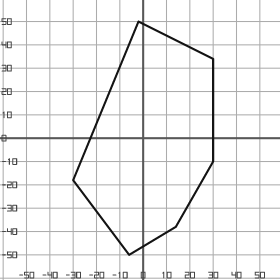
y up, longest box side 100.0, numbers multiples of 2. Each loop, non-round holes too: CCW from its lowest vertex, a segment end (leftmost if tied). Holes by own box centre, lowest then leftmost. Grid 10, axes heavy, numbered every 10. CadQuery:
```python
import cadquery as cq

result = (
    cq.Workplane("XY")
    .moveTo(-6.0, -50.0)
    .lineTo(14.0, -38.0)
    .lineTo(30.0, -10.0)
    .lineTo(30.0, 34.0)
    .lineTo(-2.0, 50.0)
    .lineTo(-30.0, -18.0)
    .close()
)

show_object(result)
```